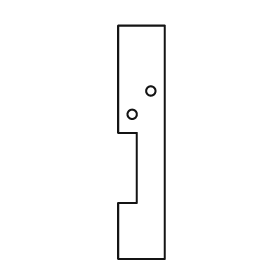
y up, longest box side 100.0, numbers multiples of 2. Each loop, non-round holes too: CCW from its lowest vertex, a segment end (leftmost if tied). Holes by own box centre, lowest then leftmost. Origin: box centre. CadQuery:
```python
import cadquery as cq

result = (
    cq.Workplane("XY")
    .moveTo(-10.0, -50.0)
    .lineTo(10.0, -50.0)
    .lineTo(10.0, 50.0)
    .lineTo(-10.0, 50.0)
    .lineTo(-10.0, 4.0)
    .lineTo(-2.0, 4.0)
    .lineTo(-2.0, -26.0)
    .lineTo(-10.0, -26.0)
    .close()
    .moveTo(-4.0, 12.0)
    .circle(2.0)
    .moveTo(4.0, 22.0)
    .circle(2.0)
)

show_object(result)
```